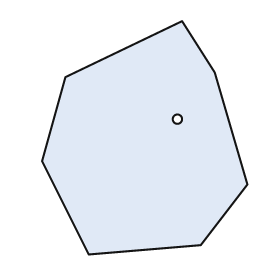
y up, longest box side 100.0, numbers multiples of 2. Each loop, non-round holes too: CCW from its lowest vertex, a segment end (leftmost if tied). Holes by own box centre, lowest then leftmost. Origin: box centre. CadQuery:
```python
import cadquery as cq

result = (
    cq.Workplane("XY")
    .moveTo(-24.0, -50.0)
    .lineTo(24.0, -46.0)
    .lineTo(44.0, -20.0)
    .lineTo(30.0, 28.0)
    .lineTo(16.0, 50.0)
    .lineTo(-34.0, 26.0)
    .lineTo(-44.0, -10.0)
    .close()
    .moveTo(14.0, 8.0)
    .circle(2.0)
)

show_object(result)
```